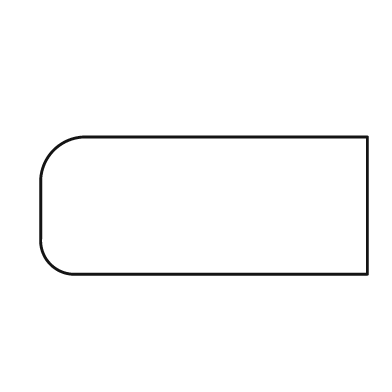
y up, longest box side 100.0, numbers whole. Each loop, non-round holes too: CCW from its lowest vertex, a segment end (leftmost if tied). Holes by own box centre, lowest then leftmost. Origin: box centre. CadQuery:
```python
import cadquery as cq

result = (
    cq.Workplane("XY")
    .moveTo(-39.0, -21.0)
    .lineTo(50.0, -21.0)
    .lineTo(50.0, 21.0)
    .lineTo(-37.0, 21.0)
    .threePointArc((-46.0, 17.0), (-50.0, 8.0))
    .lineTo(-50.0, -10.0)
    .threePointArc((-47.0, -18.0), (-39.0, -21.0))
    .close()
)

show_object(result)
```